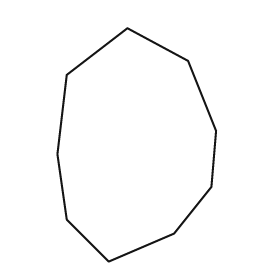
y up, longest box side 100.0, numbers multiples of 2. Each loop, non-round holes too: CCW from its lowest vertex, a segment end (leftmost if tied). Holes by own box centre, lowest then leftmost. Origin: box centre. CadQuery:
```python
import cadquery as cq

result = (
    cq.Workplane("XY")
    .moveTo(-12.0, -50.0)
    .lineTo(16.0, -38.0)
    .lineTo(32.0, -18.0)
    .lineTo(34.0, 6.0)
    .lineTo(22.0, 36.0)
    .lineTo(-4.0, 50.0)
    .lineTo(-30.0, 30.0)
    .lineTo(-34.0, -4.0)
    .lineTo(-30.0, -32.0)
    .close()
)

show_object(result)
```